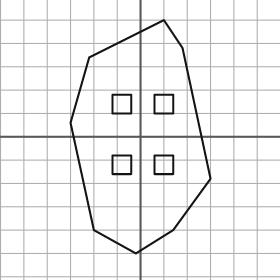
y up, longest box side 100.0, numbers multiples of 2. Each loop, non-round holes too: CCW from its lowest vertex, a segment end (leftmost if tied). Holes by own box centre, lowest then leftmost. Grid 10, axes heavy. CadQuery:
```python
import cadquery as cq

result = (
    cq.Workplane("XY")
    .moveTo(-2.0, -50.0)
    .lineTo(14.0, -40.0)
    .lineTo(30.0, -18.0)
    .lineTo(18.0, 38.0)
    .lineTo(10.0, 50.0)
    .lineTo(-22.0, 34.0)
    .lineTo(-30.0, 6.0)
    .lineTo(-20.0, -40.0)
    .close()
    .moveTo(-12.0, -16.0)
    .lineTo(-4.0, -16.0)
    .lineTo(-4.0, -8.0)
    .lineTo(-12.0, -8.0)
    .close()
    .moveTo(6.0, -16.0)
    .lineTo(14.0, -16.0)
    .lineTo(14.0, -8.0)
    .lineTo(6.0, -8.0)
    .close()
    .moveTo(-12.0, 10.0)
    .lineTo(-4.0, 10.0)
    .lineTo(-4.0, 18.0)
    .lineTo(-12.0, 18.0)
    .close()
    .moveTo(6.0, 10.0)
    .lineTo(14.0, 10.0)
    .lineTo(14.0, 18.0)
    .lineTo(6.0, 18.0)
    .close()
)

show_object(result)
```